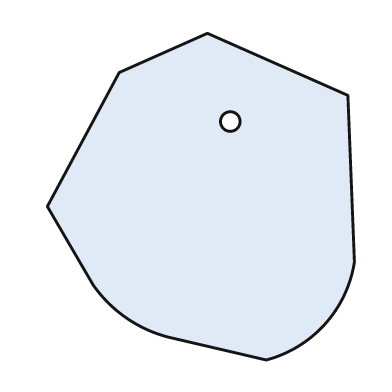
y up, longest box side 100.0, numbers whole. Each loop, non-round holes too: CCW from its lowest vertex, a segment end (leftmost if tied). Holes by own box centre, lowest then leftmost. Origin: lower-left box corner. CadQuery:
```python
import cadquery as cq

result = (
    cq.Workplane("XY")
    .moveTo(67.0, 0.0)
    .threePointArc((85.0, 11.0), (94.0, 30.0))
    .lineTo(92.0, 81.0)
    .lineTo(49.0, 100.0)
    .lineTo(22.0, 88.0)
    .lineTo(0.0, 47.0)
    .lineTo(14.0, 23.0)
    .threePointArc((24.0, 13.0), (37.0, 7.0))
    .close()
    .moveTo(56.0, 73.0)
    .circle(3.0)
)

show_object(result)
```